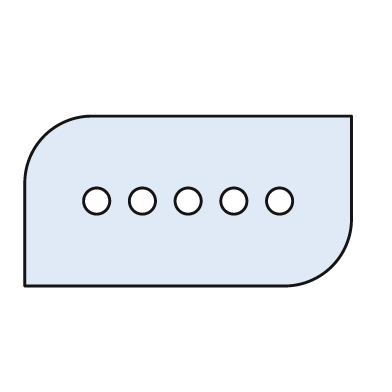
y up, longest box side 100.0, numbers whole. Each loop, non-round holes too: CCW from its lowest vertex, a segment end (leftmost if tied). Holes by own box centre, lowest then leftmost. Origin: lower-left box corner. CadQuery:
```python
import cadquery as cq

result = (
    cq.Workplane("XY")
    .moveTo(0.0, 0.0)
    .lineTo(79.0, 0.0)
    .threePointArc((94.0, 6.0), (100.0, 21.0))
    .lineTo(100.0, 52.0)
    .lineTo(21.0, 52.0)
    .threePointArc((6.0, 46.0), (0.0, 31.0))
    .close()
    .moveTo(22.0, 26.0)
    .circle(4.0)
    .moveTo(36.0, 26.0)
    .circle(4.0)
    .moveTo(50.0, 26.0)
    .circle(4.0)
    .moveTo(64.0, 26.0)
    .circle(4.0)
    .moveTo(78.0, 26.0)
    .circle(4.0)
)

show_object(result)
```